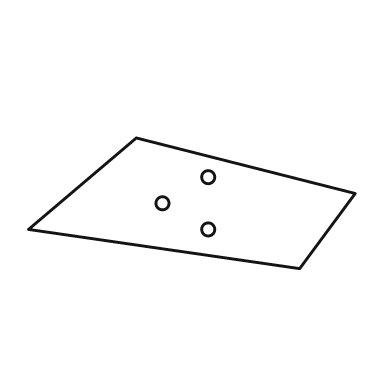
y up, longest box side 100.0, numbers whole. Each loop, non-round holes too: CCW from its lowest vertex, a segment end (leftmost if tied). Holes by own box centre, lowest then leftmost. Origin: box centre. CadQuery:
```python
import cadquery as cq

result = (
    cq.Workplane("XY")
    .moveTo(33.0, -20.0)
    .lineTo(50.0, 3.0)
    .lineTo(-17.0, 20.0)
    .lineTo(-50.0, -8.0)
    .close()
    .moveTo(5.0, -8.0)
    .circle(2.0)
    .moveTo(-9.0, 0.0)
    .circle(2.0)
    .moveTo(5.0, 8.0)
    .circle(2.0)
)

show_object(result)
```